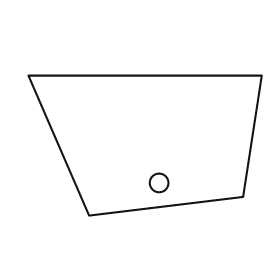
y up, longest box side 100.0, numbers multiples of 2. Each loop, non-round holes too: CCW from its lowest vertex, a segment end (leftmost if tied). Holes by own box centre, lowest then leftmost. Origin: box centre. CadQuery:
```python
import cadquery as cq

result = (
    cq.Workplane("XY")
    .moveTo(-24.0, -30.0)
    .lineTo(42.0, -22.0)
    .lineTo(50.0, 30.0)
    .lineTo(-50.0, 30.0)
    .close()
    .moveTo(6.0, -16.0)
    .circle(4.0)
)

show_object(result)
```